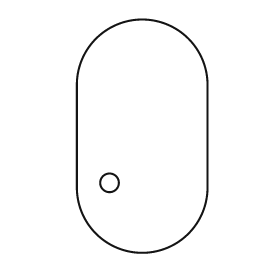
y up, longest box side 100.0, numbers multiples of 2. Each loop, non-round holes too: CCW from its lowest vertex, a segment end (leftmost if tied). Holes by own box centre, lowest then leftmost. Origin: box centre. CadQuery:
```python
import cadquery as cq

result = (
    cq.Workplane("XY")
    .moveTo(-28.0, -22.0)
    .threePointArc((0.0, -50.0), (28.0, -22.0))
    .lineTo(28.0, 22.0)
    .threePointArc((0.0, 50.0), (-28.0, 22.0))
    .close()
    .moveTo(-14.0, -20.0)
    .circle(4.0)
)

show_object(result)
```